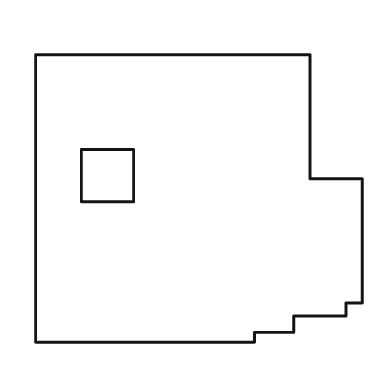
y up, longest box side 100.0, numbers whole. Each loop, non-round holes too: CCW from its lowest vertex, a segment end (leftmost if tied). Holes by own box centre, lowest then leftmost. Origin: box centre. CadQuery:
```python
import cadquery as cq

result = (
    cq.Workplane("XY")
    .moveTo(-50.0, -44.0)
    .lineTo(17.0, -44.0)
    .lineTo(17.0, -41.0)
    .lineTo(29.0, -41.0)
    .lineTo(29.0, -36.0)
    .lineTo(45.0, -36.0)
    .lineTo(45.0, -32.0)
    .lineTo(50.0, -32.0)
    .lineTo(50.0, 6.0)
    .lineTo(34.0, 6.0)
    .lineTo(34.0, 44.0)
    .lineTo(-50.0, 44.0)
    .close()
    .moveTo(-36.0, -1.0)
    .lineTo(-20.0, -1.0)
    .lineTo(-20.0, 15.0)
    .lineTo(-36.0, 15.0)
    .close()
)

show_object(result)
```